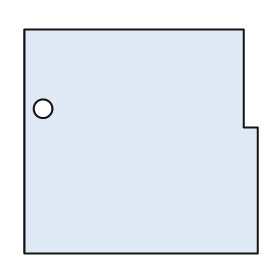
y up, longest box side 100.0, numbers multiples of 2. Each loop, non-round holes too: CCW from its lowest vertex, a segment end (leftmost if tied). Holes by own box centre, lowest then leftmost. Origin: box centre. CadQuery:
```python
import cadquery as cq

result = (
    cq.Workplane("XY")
    .moveTo(-50.0, -48.0)
    .lineTo(50.0, -48.0)
    .lineTo(50.0, 6.0)
    .lineTo(44.0, 6.0)
    .lineTo(44.0, 48.0)
    .lineTo(-50.0, 48.0)
    .close()
    .moveTo(-42.0, 14.0)
    .circle(4.0)
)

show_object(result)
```